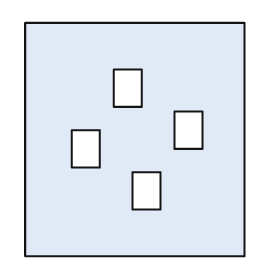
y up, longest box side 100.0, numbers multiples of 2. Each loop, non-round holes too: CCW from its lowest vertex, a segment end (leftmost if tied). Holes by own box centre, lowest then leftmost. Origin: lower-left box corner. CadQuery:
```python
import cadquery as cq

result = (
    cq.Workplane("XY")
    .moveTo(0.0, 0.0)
    .lineTo(94.0, 0.0)
    .lineTo(94.0, 100.0)
    .lineTo(0.0, 100.0)
    .close()
    .moveTo(46.0, 20.0)
    .lineTo(58.0, 20.0)
    .lineTo(58.0, 36.0)
    .lineTo(46.0, 36.0)
    .close()
    .moveTo(20.0, 38.0)
    .lineTo(32.0, 38.0)
    .lineTo(32.0, 54.0)
    .lineTo(20.0, 54.0)
    .close()
    .moveTo(64.0, 46.0)
    .lineTo(76.0, 46.0)
    .lineTo(76.0, 62.0)
    .lineTo(64.0, 62.0)
    .close()
    .moveTo(38.0, 64.0)
    .lineTo(50.0, 64.0)
    .lineTo(50.0, 80.0)
    .lineTo(38.0, 80.0)
    .close()
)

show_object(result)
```